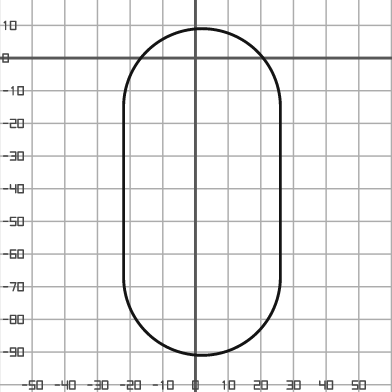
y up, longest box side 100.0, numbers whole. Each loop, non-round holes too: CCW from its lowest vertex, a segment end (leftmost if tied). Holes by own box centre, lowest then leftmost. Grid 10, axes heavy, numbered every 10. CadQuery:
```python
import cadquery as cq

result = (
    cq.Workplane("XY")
    .moveTo(-22.0, -67.0)
    .threePointArc((2.0, -91.0), (26.0, -67.0))
    .lineTo(26.0, -15.0)
    .threePointArc((2.0, 9.0), (-22.0, -15.0))
    .close()
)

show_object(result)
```